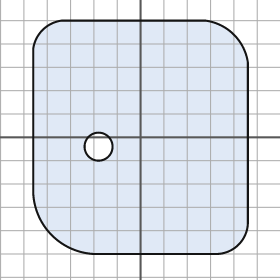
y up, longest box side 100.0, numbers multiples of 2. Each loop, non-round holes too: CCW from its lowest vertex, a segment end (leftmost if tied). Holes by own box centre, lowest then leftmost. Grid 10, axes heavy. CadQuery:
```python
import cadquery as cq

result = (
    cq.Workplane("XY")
    .moveTo(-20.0, -50.0)
    .lineTo(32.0, -50.0)
    .threePointArc((42.0, -46.0), (46.0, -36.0))
    .lineTo(46.0, 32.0)
    .threePointArc((40.0, 44.0), (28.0, 50.0))
    .lineTo(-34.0, 50.0)
    .threePointArc((-42.0, 46.0), (-46.0, 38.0))
    .lineTo(-46.0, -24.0)
    .threePointArc((-38.0, -42.0), (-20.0, -50.0))
    .close()
    .moveTo(-18.0, -4.0)
    .circle(6.0)
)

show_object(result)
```